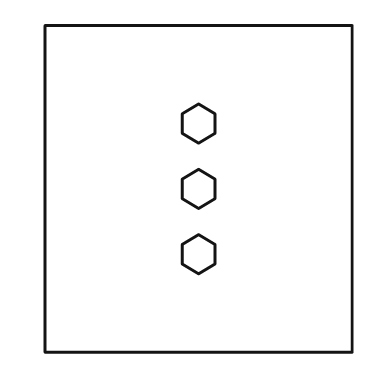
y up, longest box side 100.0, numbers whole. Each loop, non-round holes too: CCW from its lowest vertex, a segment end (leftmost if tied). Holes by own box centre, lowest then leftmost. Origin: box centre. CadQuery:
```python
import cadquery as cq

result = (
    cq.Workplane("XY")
    .moveTo(-47.0, -50.0)
    .lineTo(47.0, -50.0)
    .lineTo(47.0, 50.0)
    .lineTo(-47.0, 50.0)
    .close()
    .moveTo(0.0, -26.0)
    .lineTo(5.0, -23.0)
    .lineTo(5.0, -17.0)
    .lineTo(0.0, -14.0)
    .lineTo(-5.0, -17.0)
    .lineTo(-5.0, -23.0)
    .close()
    .moveTo(0.0, -6.0)
    .lineTo(5.0, -3.0)
    .lineTo(5.0, 3.0)
    .lineTo(0.0, 6.0)
    .lineTo(-5.0, 3.0)
    .lineTo(-5.0, -3.0)
    .close()
    .moveTo(0.0, 14.0)
    .lineTo(5.0, 17.0)
    .lineTo(5.0, 23.0)
    .lineTo(0.0, 26.0)
    .lineTo(-5.0, 23.0)
    .lineTo(-5.0, 17.0)
    .close()
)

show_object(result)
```